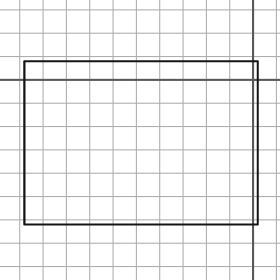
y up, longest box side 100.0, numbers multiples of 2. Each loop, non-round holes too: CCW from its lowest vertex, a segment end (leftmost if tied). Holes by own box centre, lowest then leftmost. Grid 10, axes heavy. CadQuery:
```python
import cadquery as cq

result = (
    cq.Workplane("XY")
    .moveTo(-98.0, -62.0)
    .lineTo(2.0, -62.0)
    .lineTo(2.0, 8.0)
    .lineTo(-98.0, 8.0)
    .close()
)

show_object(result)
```